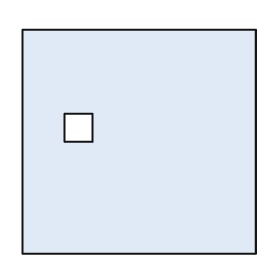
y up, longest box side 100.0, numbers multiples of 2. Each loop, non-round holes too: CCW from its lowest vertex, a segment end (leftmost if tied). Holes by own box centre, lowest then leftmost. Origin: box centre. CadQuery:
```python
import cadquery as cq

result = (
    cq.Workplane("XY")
    .moveTo(-50.0, -48.0)
    .lineTo(50.0, -48.0)
    .lineTo(50.0, 48.0)
    .lineTo(-50.0, 48.0)
    .close()
    .moveTo(-32.0, 0.0)
    .lineTo(-20.0, 0.0)
    .lineTo(-20.0, 12.0)
    .lineTo(-32.0, 12.0)
    .close()
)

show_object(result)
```